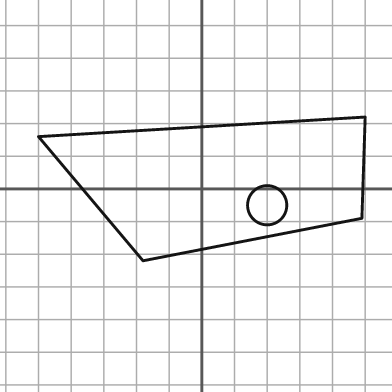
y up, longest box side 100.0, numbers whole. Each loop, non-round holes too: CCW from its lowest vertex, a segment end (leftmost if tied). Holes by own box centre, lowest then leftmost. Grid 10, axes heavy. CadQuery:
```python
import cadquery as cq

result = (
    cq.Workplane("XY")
    .moveTo(-18.0, -22.0)
    .lineTo(49.0, -9.0)
    .lineTo(50.0, 22.0)
    .lineTo(-50.0, 16.0)
    .close()
    .moveTo(20.0, -5.0)
    .circle(6.0)
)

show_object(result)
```